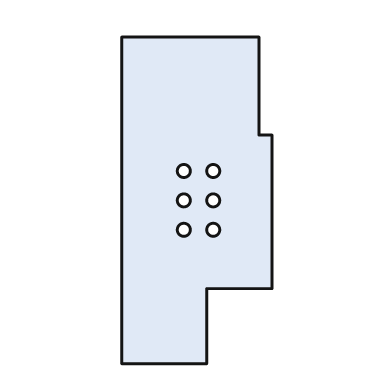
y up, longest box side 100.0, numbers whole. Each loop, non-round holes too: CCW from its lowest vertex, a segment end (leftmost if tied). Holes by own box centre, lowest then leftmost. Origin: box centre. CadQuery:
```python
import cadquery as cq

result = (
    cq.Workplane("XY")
    .moveTo(-23.0, -50.0)
    .lineTo(3.0, -50.0)
    .lineTo(3.0, -27.0)
    .lineTo(23.0, -27.0)
    .lineTo(23.0, 20.0)
    .lineTo(19.0, 20.0)
    .lineTo(19.0, 50.0)
    .lineTo(-23.0, 50.0)
    .close()
    .moveTo(-4.0, -9.0)
    .circle(2.0)
    .moveTo(5.0, -9.0)
    .circle(2.0)
    .moveTo(-4.0, 0.0)
    .circle(2.0)
    .moveTo(5.0, 0.0)
    .circle(2.0)
    .moveTo(-4.0, 9.0)
    .circle(2.0)
    .moveTo(5.0, 9.0)
    .circle(2.0)
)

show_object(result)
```